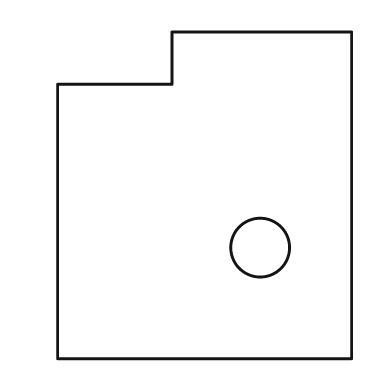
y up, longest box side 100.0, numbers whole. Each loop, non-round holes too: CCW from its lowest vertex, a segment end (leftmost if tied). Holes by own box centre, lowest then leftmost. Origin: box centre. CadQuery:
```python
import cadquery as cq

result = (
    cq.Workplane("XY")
    .moveTo(-45.0, -50.0)
    .lineTo(45.0, -50.0)
    .lineTo(45.0, 50.0)
    .lineTo(-10.0, 50.0)
    .lineTo(-10.0, 34.0)
    .lineTo(-45.0, 34.0)
    .close()
    .moveTo(17.0, -16.0)
    .circle(9.0)
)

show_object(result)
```